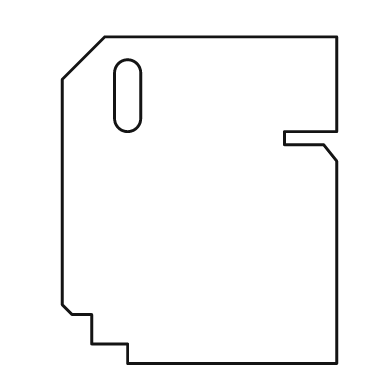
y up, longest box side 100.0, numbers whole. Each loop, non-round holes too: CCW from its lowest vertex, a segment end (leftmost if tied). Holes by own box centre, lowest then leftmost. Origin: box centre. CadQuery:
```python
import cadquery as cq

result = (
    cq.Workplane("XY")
    .moveTo(-22.0, -50.0)
    .lineTo(42.0, -50.0)
    .lineTo(42.0, 12.0)
    .lineTo(38.0, 17.0)
    .lineTo(26.0, 17.0)
    .lineTo(26.0, 21.0)
    .lineTo(42.0, 21.0)
    .lineTo(42.0, 50.0)
    .lineTo(-29.0, 50.0)
    .lineTo(-42.0, 37.0)
    .lineTo(-42.0, -32.0)
    .lineTo(-39.0, -35.0)
    .lineTo(-33.0, -35.0)
    .lineTo(-33.0, -44.0)
    .lineTo(-22.0, -44.0)
    .close()
    .moveTo(-26.0, 25.0)
    .threePointArc((-22.0, 21.0), (-18.0, 25.0))
    .lineTo(-18.0, 39.0)
    .threePointArc((-22.0, 43.0), (-26.0, 39.0))
    .close()
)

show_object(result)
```